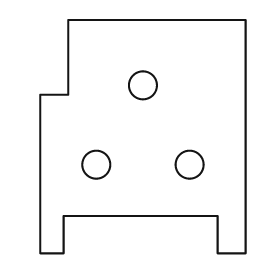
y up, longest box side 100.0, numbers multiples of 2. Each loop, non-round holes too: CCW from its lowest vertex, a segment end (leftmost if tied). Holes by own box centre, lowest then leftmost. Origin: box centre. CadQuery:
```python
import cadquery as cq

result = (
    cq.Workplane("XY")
    .moveTo(-44.0, -50.0)
    .lineTo(-34.0, -50.0)
    .lineTo(-34.0, -34.0)
    .lineTo(32.0, -34.0)
    .lineTo(32.0, -50.0)
    .lineTo(44.0, -50.0)
    .lineTo(44.0, 50.0)
    .lineTo(-32.0, 50.0)
    .lineTo(-32.0, 18.0)
    .lineTo(-44.0, 18.0)
    .close()
    .moveTo(-20.0, -12.0)
    .circle(6.0)
    .moveTo(20.0, -12.0)
    .circle(6.0)
    .moveTo(0.0, 22.0)
    .circle(6.0)
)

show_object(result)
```